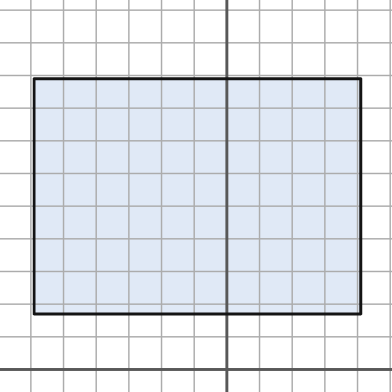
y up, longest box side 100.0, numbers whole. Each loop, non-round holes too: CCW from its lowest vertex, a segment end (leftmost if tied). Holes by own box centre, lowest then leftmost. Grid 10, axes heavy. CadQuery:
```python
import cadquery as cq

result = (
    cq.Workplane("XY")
    .moveTo(-59.0, 17.0)
    .lineTo(41.0, 17.0)
    .lineTo(41.0, 89.0)
    .lineTo(-59.0, 89.0)
    .close()
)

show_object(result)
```